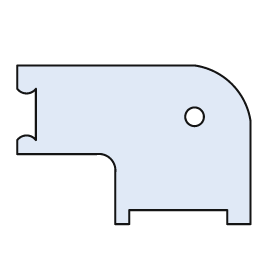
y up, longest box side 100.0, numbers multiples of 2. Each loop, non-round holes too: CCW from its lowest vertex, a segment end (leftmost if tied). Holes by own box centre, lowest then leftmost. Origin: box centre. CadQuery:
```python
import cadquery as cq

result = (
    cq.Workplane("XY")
    .moveTo(-8.0, -34.0)
    .lineTo(-2.0, -34.0)
    .lineTo(-2.0, -28.0)
    .lineTo(40.0, -28.0)
    .lineTo(40.0, -34.0)
    .lineTo(50.0, -34.0)
    .lineTo(50.0, 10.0)
    .threePointArc((42.0, 26.0), (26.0, 34.0))
    .lineTo(-50.0, 34.0)
    .lineTo(-50.0, 24.0)
    .threePointArc((-46.0, 22.0), (-42.0, 24.0))
    .lineTo(-42.0, 2.0)
    .threePointArc((-46.0, 4.0), (-50.0, 2.0))
    .lineTo(-50.0, -4.0)
    .lineTo(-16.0, -4.0)
    .threePointArc((-10.0, -6.0), (-8.0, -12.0))
    .close()
    .moveTo(26.0, 12.0)
    .circle(4.0)
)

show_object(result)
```